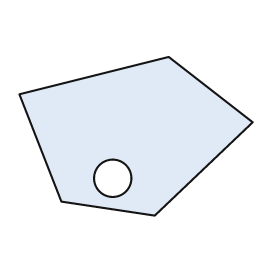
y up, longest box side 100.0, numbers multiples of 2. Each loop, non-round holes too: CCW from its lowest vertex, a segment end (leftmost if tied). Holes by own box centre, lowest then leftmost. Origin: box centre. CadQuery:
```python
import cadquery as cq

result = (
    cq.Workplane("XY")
    .moveTo(8.0, -34.0)
    .lineTo(50.0, 6.0)
    .lineTo(14.0, 34.0)
    .lineTo(-50.0, 18.0)
    .lineTo(-32.0, -28.0)
    .close()
    .moveTo(-10.0, -18.0)
    .circle(8.0)
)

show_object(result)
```